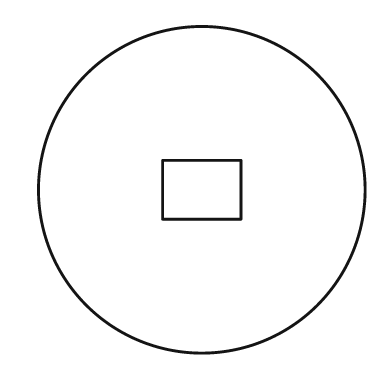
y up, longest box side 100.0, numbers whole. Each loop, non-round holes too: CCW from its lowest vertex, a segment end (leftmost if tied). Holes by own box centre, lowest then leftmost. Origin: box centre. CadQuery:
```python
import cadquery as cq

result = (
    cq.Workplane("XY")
    .moveTo(0.0, 0.0)
    .circle(50.0)
    .moveTo(-12.0, -9.0)
    .lineTo(12.0, -9.0)
    .lineTo(12.0, 9.0)
    .lineTo(-12.0, 9.0)
    .close()
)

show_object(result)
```